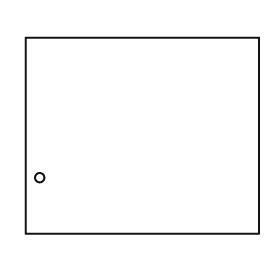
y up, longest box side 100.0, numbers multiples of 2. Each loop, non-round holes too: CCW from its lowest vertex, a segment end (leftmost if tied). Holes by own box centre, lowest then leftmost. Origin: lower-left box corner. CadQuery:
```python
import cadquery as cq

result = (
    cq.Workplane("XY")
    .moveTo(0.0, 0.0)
    .lineTo(100.0, 0.0)
    .lineTo(100.0, 84.0)
    .lineTo(0.0, 84.0)
    .close()
    .moveTo(6.0, 24.0)
    .circle(2.0)
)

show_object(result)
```